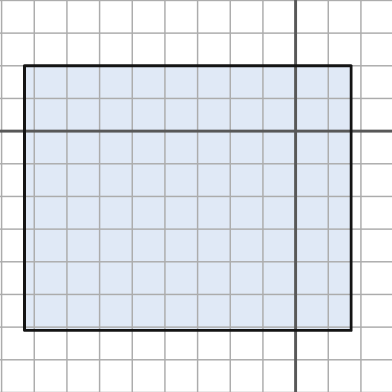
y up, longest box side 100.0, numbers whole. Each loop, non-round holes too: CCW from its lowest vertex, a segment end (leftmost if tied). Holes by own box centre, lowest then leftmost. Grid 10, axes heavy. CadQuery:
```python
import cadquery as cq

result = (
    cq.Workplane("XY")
    .moveTo(-83.0, -61.0)
    .lineTo(17.0, -61.0)
    .lineTo(17.0, 20.0)
    .lineTo(-83.0, 20.0)
    .close()
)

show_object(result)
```